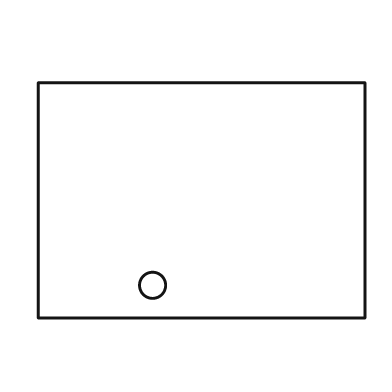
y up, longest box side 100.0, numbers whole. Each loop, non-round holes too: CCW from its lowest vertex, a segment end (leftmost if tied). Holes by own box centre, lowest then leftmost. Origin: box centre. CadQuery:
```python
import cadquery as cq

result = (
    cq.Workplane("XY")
    .moveTo(-50.0, -36.0)
    .lineTo(50.0, -36.0)
    .lineTo(50.0, 36.0)
    .lineTo(-50.0, 36.0)
    .close()
    .moveTo(-15.0, -26.0)
    .circle(4.0)
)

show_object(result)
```